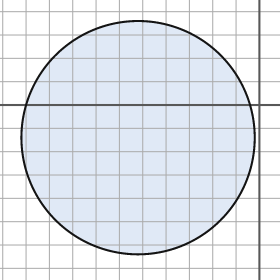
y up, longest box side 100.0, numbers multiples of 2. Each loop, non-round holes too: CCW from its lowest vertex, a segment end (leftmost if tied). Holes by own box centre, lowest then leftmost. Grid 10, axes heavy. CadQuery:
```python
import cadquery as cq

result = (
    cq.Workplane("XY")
    .moveTo(-52.0, -14.0)
    .circle(50.0)
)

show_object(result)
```